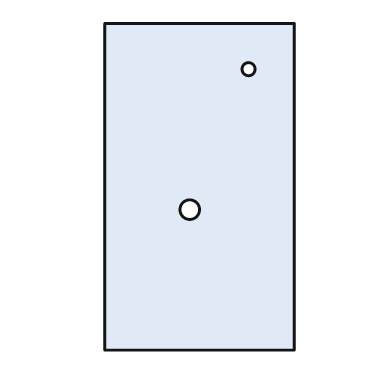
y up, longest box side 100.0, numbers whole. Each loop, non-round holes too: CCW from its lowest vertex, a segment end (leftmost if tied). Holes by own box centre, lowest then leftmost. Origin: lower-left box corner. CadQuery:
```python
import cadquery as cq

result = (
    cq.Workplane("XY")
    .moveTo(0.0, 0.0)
    .lineTo(58.0, 0.0)
    .lineTo(58.0, 100.0)
    .lineTo(0.0, 100.0)
    .close()
    .moveTo(26.0, 43.0)
    .circle(3.0)
    .moveTo(44.0, 86.0)
    .circle(2.0)
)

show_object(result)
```